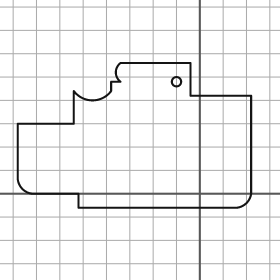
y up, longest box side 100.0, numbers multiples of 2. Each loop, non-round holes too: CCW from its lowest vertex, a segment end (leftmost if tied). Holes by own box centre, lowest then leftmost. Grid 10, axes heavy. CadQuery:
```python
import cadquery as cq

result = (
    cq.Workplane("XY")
    .moveTo(-52.0, -6.0)
    .lineTo(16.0, -6.0)
    .threePointArc((20.0, -4.0), (22.0, 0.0))
    .lineTo(22.0, 42.0)
    .lineTo(-4.0, 42.0)
    .lineTo(-4.0, 56.0)
    .lineTo(-34.0, 56.0)
    .threePointArc((-36.0, 52.0), (-34.0, 48.0))
    .lineTo(-38.0, 48.0)
    .lineTo(-38.0, 44.0)
    .threePointArc((-46.0, 40.0), (-54.0, 44.0))
    .lineTo(-54.0, 30.0)
    .lineTo(-78.0, 30.0)
    .lineTo(-78.0, 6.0)
    .threePointArc((-76.0, 2.0), (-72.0, 0.0))
    .lineTo(-52.0, 0.0)
    .close()
    .moveTo(-10.0, 48.0)
    .circle(2.0)
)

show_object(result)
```